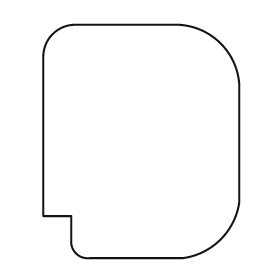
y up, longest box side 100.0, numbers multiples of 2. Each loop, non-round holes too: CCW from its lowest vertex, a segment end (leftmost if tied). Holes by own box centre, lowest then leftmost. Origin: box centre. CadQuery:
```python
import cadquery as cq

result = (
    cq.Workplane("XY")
    .moveTo(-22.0, -50.0)
    .lineTo(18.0, -50.0)
    .threePointArc((34.0, -42.0), (42.0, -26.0))
    .lineTo(42.0, 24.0)
    .threePointArc((34.0, 42.0), (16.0, 50.0))
    .lineTo(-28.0, 50.0)
    .threePointArc((-38.0, 46.0), (-42.0, 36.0))
    .lineTo(-42.0, -32.0)
    .lineTo(-30.0, -32.0)
    .lineTo(-30.0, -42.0)
    .threePointArc((-28.0, -48.0), (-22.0, -50.0))
    .close()
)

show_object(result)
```